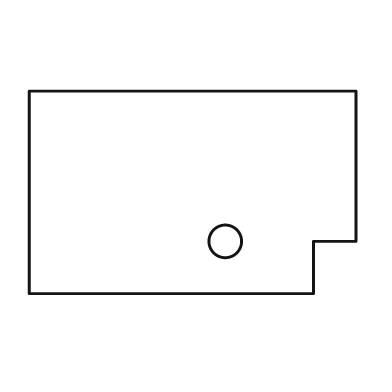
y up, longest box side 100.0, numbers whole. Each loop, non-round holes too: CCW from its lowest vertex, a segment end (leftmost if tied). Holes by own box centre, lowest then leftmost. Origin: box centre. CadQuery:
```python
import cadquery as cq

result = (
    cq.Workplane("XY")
    .moveTo(-50.0, -31.0)
    .lineTo(37.0, -31.0)
    .lineTo(37.0, -15.0)
    .lineTo(50.0, -15.0)
    .lineTo(50.0, 31.0)
    .lineTo(-50.0, 31.0)
    .close()
    .moveTo(10.0, -15.0)
    .circle(5.0)
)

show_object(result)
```